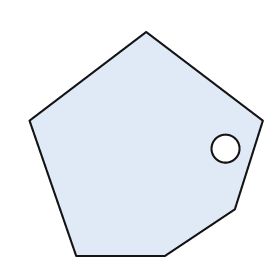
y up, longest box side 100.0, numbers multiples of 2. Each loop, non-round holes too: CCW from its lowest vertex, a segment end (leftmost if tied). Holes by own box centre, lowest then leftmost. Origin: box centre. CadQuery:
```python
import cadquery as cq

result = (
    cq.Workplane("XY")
    .moveTo(-30.0, -48.0)
    .lineTo(8.0, -48.0)
    .lineTo(38.0, -28.0)
    .lineTo(50.0, 10.0)
    .lineTo(0.0, 48.0)
    .lineTo(-50.0, 10.0)
    .close()
    .moveTo(34.0, -2.0)
    .circle(6.0)
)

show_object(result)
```